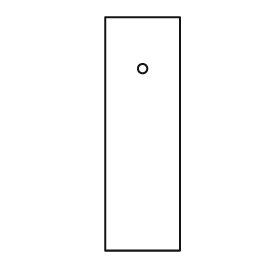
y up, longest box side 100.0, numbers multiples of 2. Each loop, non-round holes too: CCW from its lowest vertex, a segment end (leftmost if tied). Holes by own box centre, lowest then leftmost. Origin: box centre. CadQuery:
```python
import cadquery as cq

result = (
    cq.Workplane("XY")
    .moveTo(-16.0, -50.0)
    .lineTo(16.0, -50.0)
    .lineTo(16.0, 50.0)
    .lineTo(-16.0, 50.0)
    .close()
    .moveTo(0.0, 28.0)
    .circle(2.0)
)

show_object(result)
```